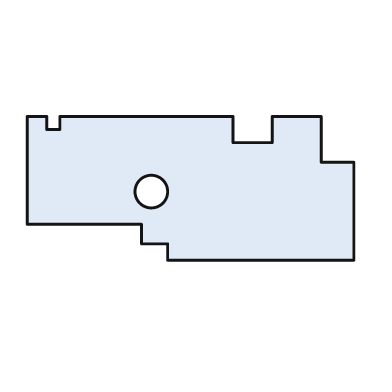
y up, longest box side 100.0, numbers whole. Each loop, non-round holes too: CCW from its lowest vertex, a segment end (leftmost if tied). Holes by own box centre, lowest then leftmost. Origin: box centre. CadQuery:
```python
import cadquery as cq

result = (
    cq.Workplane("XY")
    .moveTo(-7.0, -22.0)
    .lineTo(50.0, -22.0)
    .lineTo(50.0, 8.0)
    .lineTo(40.0, 8.0)
    .lineTo(40.0, 22.0)
    .lineTo(25.0, 22.0)
    .lineTo(25.0, 14.0)
    .lineTo(13.0, 14.0)
    .lineTo(13.0, 22.0)
    .lineTo(-40.0, 22.0)
    .lineTo(-40.0, 18.0)
    .lineTo(-44.0, 18.0)
    .lineTo(-44.0, 22.0)
    .lineTo(-50.0, 22.0)
    .lineTo(-50.0, -11.0)
    .lineTo(-15.0, -11.0)
    .lineTo(-15.0, -17.0)
    .lineTo(-7.0, -17.0)
    .close()
    .moveTo(-12.0, -1.0)
    .circle(5.0)
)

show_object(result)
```